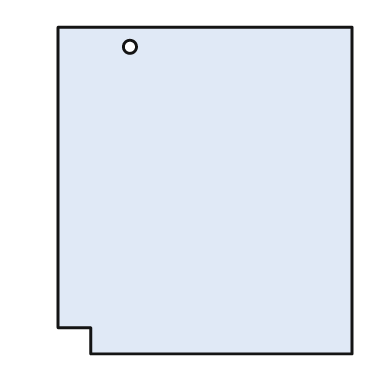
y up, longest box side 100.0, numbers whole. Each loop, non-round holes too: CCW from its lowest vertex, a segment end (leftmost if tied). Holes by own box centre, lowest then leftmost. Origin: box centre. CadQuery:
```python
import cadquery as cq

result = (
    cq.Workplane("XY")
    .moveTo(-35.0, -50.0)
    .lineTo(45.0, -50.0)
    .lineTo(45.0, 50.0)
    .lineTo(-45.0, 50.0)
    .lineTo(-45.0, -42.0)
    .lineTo(-35.0, -42.0)
    .close()
    .moveTo(-23.0, 44.0)
    .circle(2.0)
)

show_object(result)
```